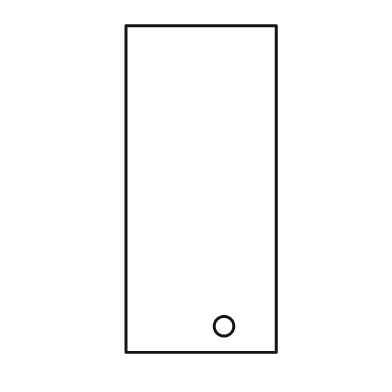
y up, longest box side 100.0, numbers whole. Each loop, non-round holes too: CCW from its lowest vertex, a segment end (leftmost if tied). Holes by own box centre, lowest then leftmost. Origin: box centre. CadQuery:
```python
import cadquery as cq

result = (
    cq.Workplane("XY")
    .moveTo(-23.0, -50.0)
    .lineTo(23.0, -50.0)
    .lineTo(23.0, 50.0)
    .lineTo(-23.0, 50.0)
    .close()
    .moveTo(7.0, -42.0)
    .circle(3.0)
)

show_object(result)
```